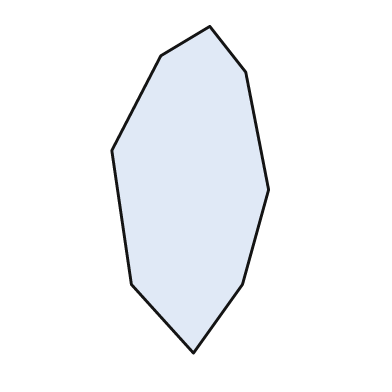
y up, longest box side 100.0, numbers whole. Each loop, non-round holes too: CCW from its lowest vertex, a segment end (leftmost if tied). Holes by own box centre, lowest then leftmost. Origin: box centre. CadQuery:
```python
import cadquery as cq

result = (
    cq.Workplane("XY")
    .moveTo(1.0, -50.0)
    .lineTo(16.0, -29.0)
    .lineTo(24.0, 0.0)
    .lineTo(17.0, 36.0)
    .lineTo(6.0, 50.0)
    .lineTo(-9.0, 41.0)
    .lineTo(-24.0, 12.0)
    .lineTo(-18.0, -29.0)
    .close()
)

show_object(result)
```